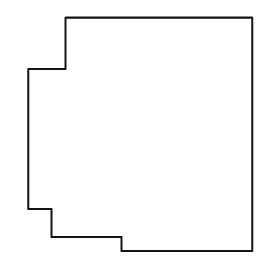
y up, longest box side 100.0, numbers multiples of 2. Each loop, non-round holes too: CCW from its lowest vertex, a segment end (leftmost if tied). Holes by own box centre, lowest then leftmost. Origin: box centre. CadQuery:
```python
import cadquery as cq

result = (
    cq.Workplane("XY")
    .moveTo(-8.0, -50.0)
    .lineTo(48.0, -50.0)
    .lineTo(48.0, 50.0)
    .lineTo(-32.0, 50.0)
    .lineTo(-32.0, 28.0)
    .lineTo(-48.0, 28.0)
    .lineTo(-48.0, -32.0)
    .lineTo(-38.0, -32.0)
    .lineTo(-38.0, -44.0)
    .lineTo(-8.0, -44.0)
    .close()
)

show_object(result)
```